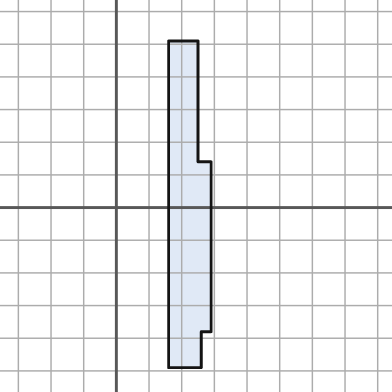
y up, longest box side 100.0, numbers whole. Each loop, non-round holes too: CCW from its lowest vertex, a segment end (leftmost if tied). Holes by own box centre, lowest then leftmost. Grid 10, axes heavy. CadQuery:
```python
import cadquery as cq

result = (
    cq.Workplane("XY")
    .moveTo(16.0, -49.0)
    .lineTo(26.0, -49.0)
    .lineTo(26.0, -38.0)
    .lineTo(29.0, -38.0)
    .lineTo(29.0, 14.0)
    .lineTo(25.0, 14.0)
    .lineTo(25.0, 51.0)
    .lineTo(16.0, 51.0)
    .close()
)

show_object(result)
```